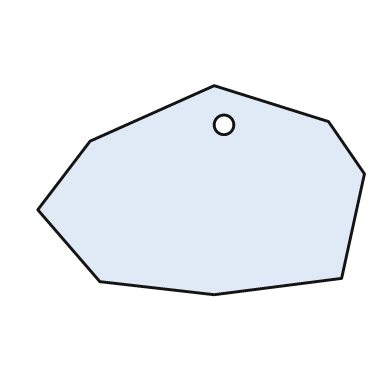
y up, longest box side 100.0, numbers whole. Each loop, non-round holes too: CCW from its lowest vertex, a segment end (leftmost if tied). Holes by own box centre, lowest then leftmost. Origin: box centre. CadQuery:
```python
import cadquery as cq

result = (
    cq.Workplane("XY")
    .moveTo(4.0, -32.0)
    .lineTo(43.0, -27.0)
    .lineTo(50.0, 5.0)
    .lineTo(39.0, 21.0)
    .lineTo(4.0, 32.0)
    .lineTo(-34.0, 15.0)
    .lineTo(-50.0, -6.0)
    .lineTo(-31.0, -28.0)
    .close()
    .moveTo(7.0, 20.0)
    .circle(3.0)
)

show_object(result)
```